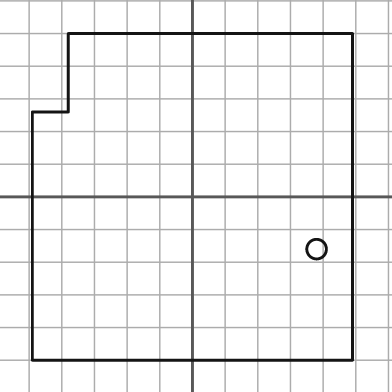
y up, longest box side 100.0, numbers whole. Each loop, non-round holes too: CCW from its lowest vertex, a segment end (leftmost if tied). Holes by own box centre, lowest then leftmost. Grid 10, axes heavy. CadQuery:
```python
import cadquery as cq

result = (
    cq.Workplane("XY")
    .moveTo(-49.0, -50.0)
    .lineTo(49.0, -50.0)
    .lineTo(49.0, 50.0)
    .lineTo(-38.0, 50.0)
    .lineTo(-38.0, 26.0)
    .lineTo(-49.0, 26.0)
    .close()
    .moveTo(38.0, -16.0)
    .circle(3.0)
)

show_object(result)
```